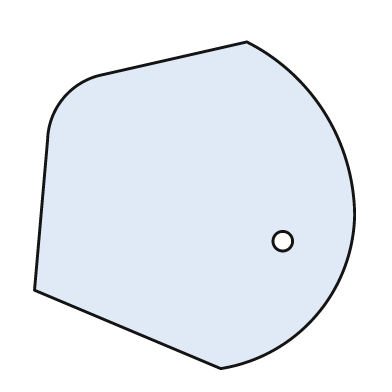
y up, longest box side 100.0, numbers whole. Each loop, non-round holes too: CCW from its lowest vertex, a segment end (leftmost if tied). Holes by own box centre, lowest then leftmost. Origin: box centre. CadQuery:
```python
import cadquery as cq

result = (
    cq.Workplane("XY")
    .moveTo(8.0, -50.0)
    .threePointArc((37.0, -34.0), (49.0, -3.0))
    .threePointArc((40.0, 28.0), (16.0, 50.0))
    .lineTo(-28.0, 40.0)
    .threePointArc((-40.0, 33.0), (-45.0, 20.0))
    .lineTo(-49.0, -26.0)
    .close()
    .moveTo(27.0, -11.0)
    .circle(3.0)
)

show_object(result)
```